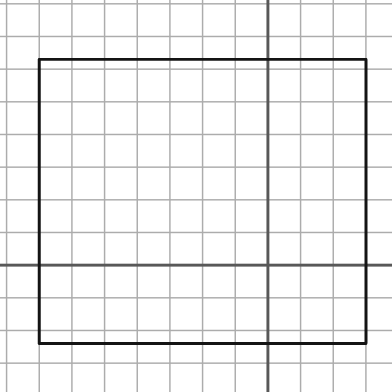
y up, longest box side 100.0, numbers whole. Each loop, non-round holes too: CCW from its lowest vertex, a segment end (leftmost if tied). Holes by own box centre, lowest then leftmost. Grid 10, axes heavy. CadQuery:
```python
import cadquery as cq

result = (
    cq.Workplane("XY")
    .moveTo(-70.0, -24.0)
    .lineTo(30.0, -24.0)
    .lineTo(30.0, 63.0)
    .lineTo(-70.0, 63.0)
    .close()
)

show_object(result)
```